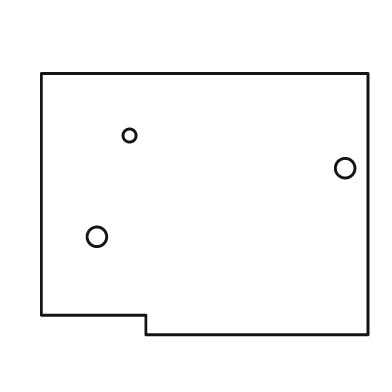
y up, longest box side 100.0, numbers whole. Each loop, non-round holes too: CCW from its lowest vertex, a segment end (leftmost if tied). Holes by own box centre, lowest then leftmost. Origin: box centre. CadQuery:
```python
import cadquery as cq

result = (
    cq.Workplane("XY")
    .moveTo(-18.0, -40.0)
    .lineTo(50.0, -40.0)
    .lineTo(50.0, 40.0)
    .lineTo(-50.0, 40.0)
    .lineTo(-50.0, -34.0)
    .lineTo(-18.0, -34.0)
    .close()
    .moveTo(-33.0, -10.0)
    .circle(3.0)
    .moveTo(43.0, 11.0)
    .circle(3.0)
    .moveTo(-23.0, 21.0)
    .circle(2.0)
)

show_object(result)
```